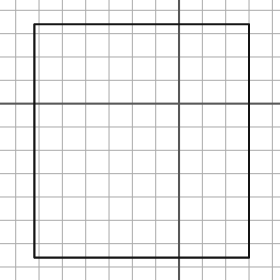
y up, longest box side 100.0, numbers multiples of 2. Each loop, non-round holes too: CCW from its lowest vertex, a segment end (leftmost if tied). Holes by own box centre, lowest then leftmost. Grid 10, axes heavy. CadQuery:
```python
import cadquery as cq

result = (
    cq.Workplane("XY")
    .moveTo(-62.0, -66.0)
    .lineTo(30.0, -66.0)
    .lineTo(30.0, 34.0)
    .lineTo(-62.0, 34.0)
    .close()
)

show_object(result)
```